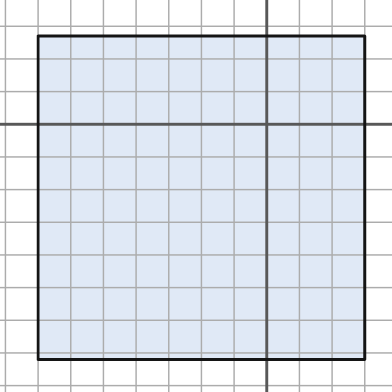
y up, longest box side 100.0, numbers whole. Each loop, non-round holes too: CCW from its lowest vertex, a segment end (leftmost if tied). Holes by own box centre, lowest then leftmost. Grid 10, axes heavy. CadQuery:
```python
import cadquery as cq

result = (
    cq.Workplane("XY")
    .moveTo(-70.0, -72.0)
    .lineTo(30.0, -72.0)
    .lineTo(30.0, 27.0)
    .lineTo(-70.0, 27.0)
    .close()
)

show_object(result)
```